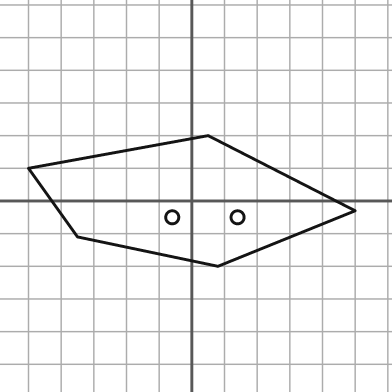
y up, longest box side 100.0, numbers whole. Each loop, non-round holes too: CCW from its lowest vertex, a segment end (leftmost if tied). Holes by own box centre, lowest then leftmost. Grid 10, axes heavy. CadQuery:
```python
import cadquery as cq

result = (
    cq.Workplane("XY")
    .moveTo(8.0, -20.0)
    .lineTo(50.0, -3.0)
    .lineTo(5.0, 20.0)
    .lineTo(-50.0, 10.0)
    .lineTo(-35.0, -11.0)
    .close()
    .moveTo(-6.0, -5.0)
    .circle(2.0)
    .moveTo(14.0, -5.0)
    .circle(2.0)
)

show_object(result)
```